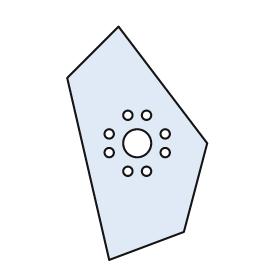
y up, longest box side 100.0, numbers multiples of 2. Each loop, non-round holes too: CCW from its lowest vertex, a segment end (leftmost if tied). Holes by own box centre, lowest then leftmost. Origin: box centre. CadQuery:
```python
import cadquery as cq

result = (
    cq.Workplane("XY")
    .moveTo(-12.0, -50.0)
    .lineTo(20.0, -38.0)
    .lineTo(30.0, 0.0)
    .lineTo(-8.0, 50.0)
    .lineTo(-30.0, 28.0)
    .close()
    .moveTo(-4.0, -12.0)
    .circle(2.0)
    .moveTo(4.0, -12.0)
    .circle(2.0)
    .moveTo(-12.0, -4.0)
    .circle(2.0)
    .moveTo(12.0, -4.0)
    .circle(2.0)
    .moveTo(0.0, 0.0)
    .circle(6.0)
    .moveTo(-12.0, 4.0)
    .circle(2.0)
    .moveTo(12.0, 4.0)
    .circle(2.0)
    .moveTo(-4.0, 12.0)
    .circle(2.0)
    .moveTo(4.0, 12.0)
    .circle(2.0)
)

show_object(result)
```